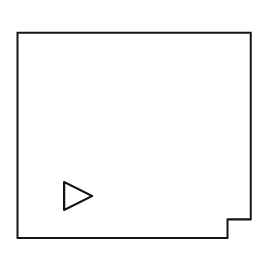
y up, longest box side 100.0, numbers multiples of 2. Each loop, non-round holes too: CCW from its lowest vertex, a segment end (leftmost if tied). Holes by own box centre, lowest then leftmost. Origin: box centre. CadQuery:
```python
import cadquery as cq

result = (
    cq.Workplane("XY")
    .moveTo(-50.0, -44.0)
    .lineTo(40.0, -44.0)
    .lineTo(40.0, -36.0)
    .lineTo(50.0, -36.0)
    .lineTo(50.0, 44.0)
    .lineTo(-50.0, 44.0)
    .close()
    .moveTo(-30.0, -32.0)
    .lineTo(-18.0, -26.0)
    .lineTo(-30.0, -20.0)
    .close()
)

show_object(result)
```